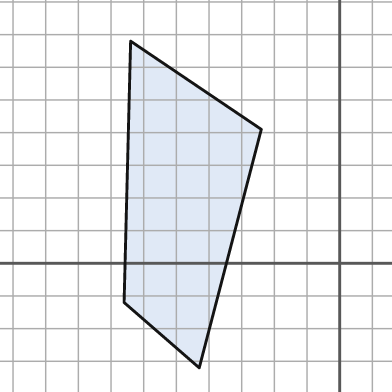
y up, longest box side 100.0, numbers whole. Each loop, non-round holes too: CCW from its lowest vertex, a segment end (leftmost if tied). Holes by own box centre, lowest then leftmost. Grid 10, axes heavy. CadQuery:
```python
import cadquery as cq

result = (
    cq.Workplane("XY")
    .moveTo(-43.0, -32.0)
    .lineTo(-24.0, 41.0)
    .lineTo(-64.0, 68.0)
    .lineTo(-66.0, -12.0)
    .close()
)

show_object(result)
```